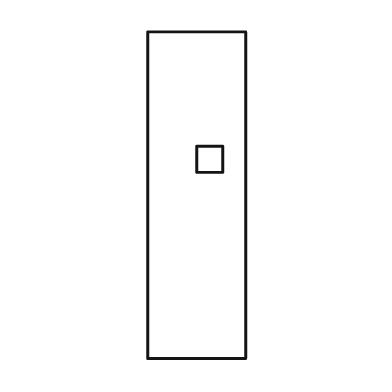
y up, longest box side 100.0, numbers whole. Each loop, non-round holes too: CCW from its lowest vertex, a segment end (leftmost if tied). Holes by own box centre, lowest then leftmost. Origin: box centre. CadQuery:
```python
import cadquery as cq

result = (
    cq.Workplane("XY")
    .moveTo(-15.0, -50.0)
    .lineTo(15.0, -50.0)
    .lineTo(15.0, 50.0)
    .lineTo(-15.0, 50.0)
    .close()
    .moveTo(0.0, 7.0)
    .lineTo(8.0, 7.0)
    .lineTo(8.0, 15.0)
    .lineTo(0.0, 15.0)
    .close()
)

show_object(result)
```